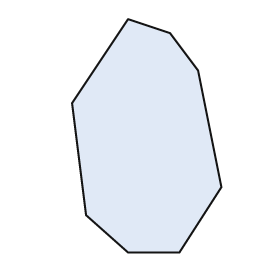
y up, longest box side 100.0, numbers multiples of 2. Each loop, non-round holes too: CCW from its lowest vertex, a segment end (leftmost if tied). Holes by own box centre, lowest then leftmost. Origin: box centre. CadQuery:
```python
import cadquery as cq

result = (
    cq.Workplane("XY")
    .moveTo(-8.0, -50.0)
    .lineTo(14.0, -50.0)
    .lineTo(32.0, -22.0)
    .lineTo(22.0, 28.0)
    .lineTo(10.0, 44.0)
    .lineTo(-8.0, 50.0)
    .lineTo(-32.0, 14.0)
    .lineTo(-26.0, -34.0)
    .close()
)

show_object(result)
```